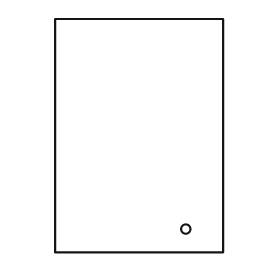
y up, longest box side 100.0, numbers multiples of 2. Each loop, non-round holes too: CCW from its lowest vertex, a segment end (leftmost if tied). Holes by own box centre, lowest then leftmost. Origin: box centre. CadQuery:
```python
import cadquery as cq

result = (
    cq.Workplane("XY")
    .moveTo(-36.0, -50.0)
    .lineTo(36.0, -50.0)
    .lineTo(36.0, 50.0)
    .lineTo(-36.0, 50.0)
    .close()
    .moveTo(20.0, -40.0)
    .circle(2.0)
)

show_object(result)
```